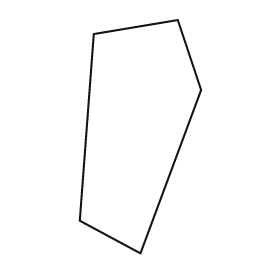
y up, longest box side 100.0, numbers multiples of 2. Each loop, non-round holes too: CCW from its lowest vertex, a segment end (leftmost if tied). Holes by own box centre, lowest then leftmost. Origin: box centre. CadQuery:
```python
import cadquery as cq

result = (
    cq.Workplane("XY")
    .moveTo(0.0, -50.0)
    .lineTo(26.0, 20.0)
    .lineTo(16.0, 50.0)
    .lineTo(-20.0, 44.0)
    .lineTo(-26.0, -36.0)
    .close()
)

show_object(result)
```